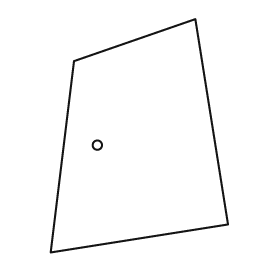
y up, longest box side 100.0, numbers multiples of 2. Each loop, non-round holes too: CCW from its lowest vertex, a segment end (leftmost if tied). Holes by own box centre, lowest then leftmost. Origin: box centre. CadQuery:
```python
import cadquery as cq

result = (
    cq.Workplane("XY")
    .moveTo(-38.0, -50.0)
    .lineTo(38.0, -38.0)
    .lineTo(24.0, 50.0)
    .lineTo(-28.0, 32.0)
    .close()
    .moveTo(-18.0, -4.0)
    .circle(2.0)
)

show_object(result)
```